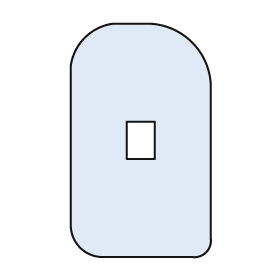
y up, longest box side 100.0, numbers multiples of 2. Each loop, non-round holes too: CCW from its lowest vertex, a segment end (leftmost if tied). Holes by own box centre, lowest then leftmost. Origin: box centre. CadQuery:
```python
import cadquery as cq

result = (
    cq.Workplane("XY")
    .moveTo(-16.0, -50.0)
    .lineTo(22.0, -50.0)
    .threePointArc((28.0, -48.0), (30.0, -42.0))
    .lineTo(30.0, 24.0)
    .threePointArc((22.0, 42.0), (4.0, 50.0))
    .lineTo(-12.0, 50.0)
    .threePointArc((-24.0, 44.0), (-30.0, 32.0))
    .lineTo(-30.0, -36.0)
    .threePointArc((-26.0, -46.0), (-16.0, -50.0))
    .close()
    .moveTo(-6.0, -8.0)
    .lineTo(6.0, -8.0)
    .lineTo(6.0, 8.0)
    .lineTo(-6.0, 8.0)
    .close()
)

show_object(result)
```